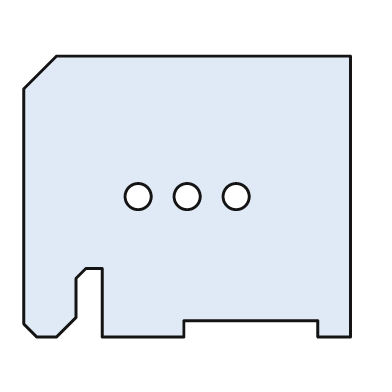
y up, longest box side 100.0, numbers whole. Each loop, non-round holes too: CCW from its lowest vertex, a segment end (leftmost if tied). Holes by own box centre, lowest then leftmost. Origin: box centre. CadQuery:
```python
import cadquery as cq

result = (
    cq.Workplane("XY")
    .moveTo(-46.0, -43.0)
    .lineTo(-40.0, -43.0)
    .lineTo(-34.0, -37.0)
    .lineTo(-34.0, -25.0)
    .lineTo(-31.0, -22.0)
    .lineTo(-26.0, -22.0)
    .lineTo(-26.0, -43.0)
    .lineTo(-1.0, -43.0)
    .lineTo(-1.0, -38.0)
    .lineTo(40.0, -38.0)
    .lineTo(40.0, -43.0)
    .lineTo(50.0, -43.0)
    .lineTo(50.0, 43.0)
    .lineTo(-40.0, 43.0)
    .lineTo(-50.0, 33.0)
    .lineTo(-50.0, -39.0)
    .close()
    .moveTo(-15.0, 0.0)
    .circle(4.0)
    .moveTo(0.0, 0.0)
    .circle(4.0)
    .moveTo(15.0, 0.0)
    .circle(4.0)
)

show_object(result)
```